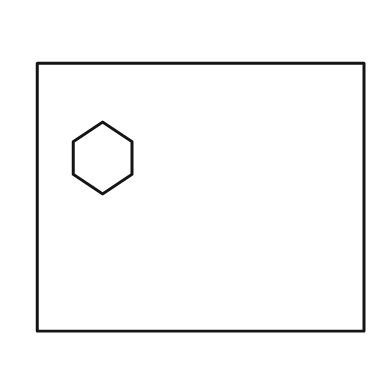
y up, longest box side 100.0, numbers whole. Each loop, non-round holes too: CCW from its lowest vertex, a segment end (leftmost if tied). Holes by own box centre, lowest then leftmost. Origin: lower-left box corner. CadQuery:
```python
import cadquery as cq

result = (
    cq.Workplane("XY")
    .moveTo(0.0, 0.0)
    .lineTo(100.0, 0.0)
    .lineTo(100.0, 82.0)
    .lineTo(0.0, 82.0)
    .close()
    .moveTo(20.0, 42.0)
    .lineTo(29.0, 48.0)
    .lineTo(29.0, 58.0)
    .lineTo(20.0, 64.0)
    .lineTo(11.0, 58.0)
    .lineTo(11.0, 48.0)
    .close()
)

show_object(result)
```